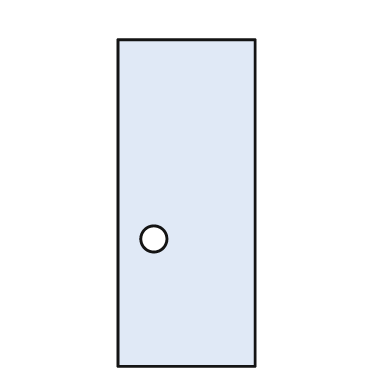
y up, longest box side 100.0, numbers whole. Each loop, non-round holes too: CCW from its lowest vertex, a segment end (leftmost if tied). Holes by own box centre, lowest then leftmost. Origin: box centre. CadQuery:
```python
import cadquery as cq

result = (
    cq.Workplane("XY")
    .moveTo(-21.0, -50.0)
    .lineTo(21.0, -50.0)
    .lineTo(21.0, 50.0)
    .lineTo(-21.0, 50.0)
    .close()
    .moveTo(-10.0, -11.0)
    .circle(4.0)
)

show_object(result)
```